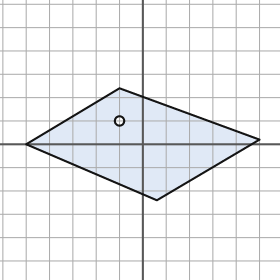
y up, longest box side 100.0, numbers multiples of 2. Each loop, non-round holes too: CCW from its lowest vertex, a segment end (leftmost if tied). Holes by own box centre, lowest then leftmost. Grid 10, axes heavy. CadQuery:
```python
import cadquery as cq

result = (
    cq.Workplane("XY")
    .moveTo(6.0, -24.0)
    .lineTo(50.0, 2.0)
    .lineTo(-10.0, 24.0)
    .lineTo(-50.0, 0.0)
    .close()
    .moveTo(-10.0, 10.0)
    .circle(2.0)
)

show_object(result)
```